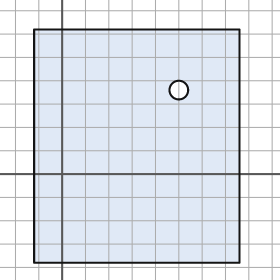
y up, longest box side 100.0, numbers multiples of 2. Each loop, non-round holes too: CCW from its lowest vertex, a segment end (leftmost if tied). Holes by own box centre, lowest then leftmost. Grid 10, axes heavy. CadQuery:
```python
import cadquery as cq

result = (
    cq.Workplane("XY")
    .moveTo(-12.0, -38.0)
    .lineTo(76.0, -38.0)
    .lineTo(76.0, 62.0)
    .lineTo(-12.0, 62.0)
    .close()
    .moveTo(50.0, 36.0)
    .circle(4.0)
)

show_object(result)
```